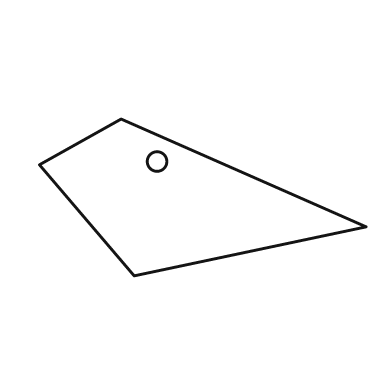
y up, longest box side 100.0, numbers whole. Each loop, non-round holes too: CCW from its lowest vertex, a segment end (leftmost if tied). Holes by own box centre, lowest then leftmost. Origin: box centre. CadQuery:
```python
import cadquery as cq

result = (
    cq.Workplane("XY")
    .moveTo(-21.0, -24.0)
    .lineTo(50.0, -9.0)
    .lineTo(-25.0, 24.0)
    .lineTo(-50.0, 10.0)
    .close()
    .moveTo(-14.0, 11.0)
    .circle(3.0)
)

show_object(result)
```